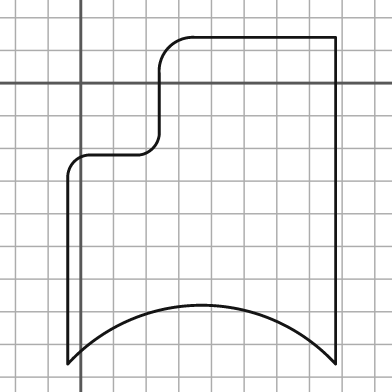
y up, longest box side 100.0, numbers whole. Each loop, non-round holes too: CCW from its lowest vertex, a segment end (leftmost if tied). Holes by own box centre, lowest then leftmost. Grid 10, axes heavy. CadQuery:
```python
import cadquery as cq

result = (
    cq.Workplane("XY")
    .moveTo(-4.0, -86.0)
    .threePointArc((37.0, -68.0), (78.0, -86.0))
    .lineTo(78.0, 14.0)
    .lineTo(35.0, 14.0)
    .threePointArc((27.0, 11.0), (24.0, 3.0))
    .lineTo(24.0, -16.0)
    .threePointArc((22.0, -20.0), (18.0, -22.0))
    .lineTo(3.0, -22.0)
    .threePointArc((-2.0, -24.0), (-4.0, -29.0))
    .close()
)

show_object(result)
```